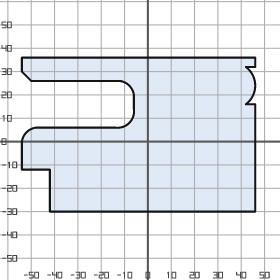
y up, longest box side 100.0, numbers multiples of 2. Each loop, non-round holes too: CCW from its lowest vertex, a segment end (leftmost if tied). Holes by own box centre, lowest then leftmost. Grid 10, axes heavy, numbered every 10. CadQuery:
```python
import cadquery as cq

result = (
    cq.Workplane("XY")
    .moveTo(-42.0, -30.0)
    .lineTo(46.0, -30.0)
    .lineTo(46.0, 16.0)
    .lineTo(42.0, 16.0)
    .threePointArc((46.0, 24.0), (42.0, 32.0))
    .lineTo(46.0, 32.0)
    .lineTo(46.0, 36.0)
    .lineTo(-54.0, 36.0)
    .lineTo(-54.0, 30.0)
    .lineTo(-50.0, 26.0)
    .lineTo(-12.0, 26.0)
    .threePointArc((-8.0, 24.0), (-6.0, 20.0))
    .lineTo(-6.0, 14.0)
    .threePointArc((-8.0, 8.0), (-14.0, 6.0))
    .lineTo(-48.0, 6.0)
    .threePointArc((-52.0, 4.0), (-54.0, 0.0))
    .lineTo(-54.0, -12.0)
    .lineTo(-42.0, -12.0)
    .close()
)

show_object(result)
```